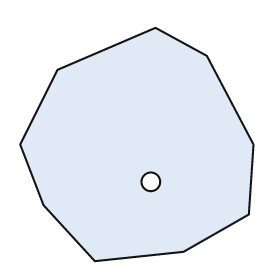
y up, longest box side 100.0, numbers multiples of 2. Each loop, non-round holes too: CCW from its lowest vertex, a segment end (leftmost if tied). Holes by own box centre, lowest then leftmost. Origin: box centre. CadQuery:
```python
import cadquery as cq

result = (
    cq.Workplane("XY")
    .moveTo(-18.0, -50.0)
    .lineTo(20.0, -46.0)
    .lineTo(48.0, -30.0)
    .lineTo(50.0, 0.0)
    .lineTo(30.0, 38.0)
    .lineTo(8.0, 50.0)
    .lineTo(-34.0, 32.0)
    .lineTo(-50.0, 0.0)
    .lineTo(-40.0, -26.0)
    .close()
    .moveTo(6.0, -16.0)
    .circle(4.0)
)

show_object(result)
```